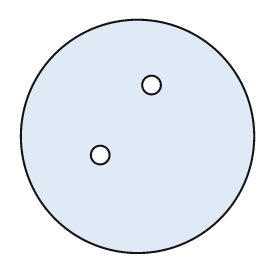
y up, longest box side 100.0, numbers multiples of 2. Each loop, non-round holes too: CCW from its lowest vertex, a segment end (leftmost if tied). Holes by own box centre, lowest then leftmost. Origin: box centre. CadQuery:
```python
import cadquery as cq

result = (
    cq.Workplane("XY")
    .moveTo(0.0, 0.0)
    .circle(50.0)
    .moveTo(-16.0, -8.0)
    .circle(4.0)
    .moveTo(6.0, 22.0)
    .circle(4.0)
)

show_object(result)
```